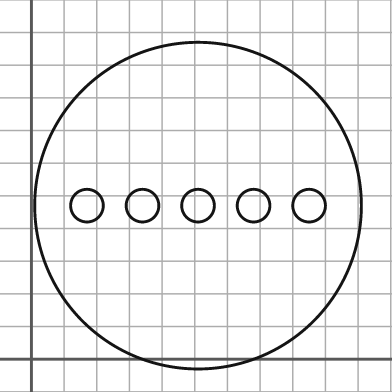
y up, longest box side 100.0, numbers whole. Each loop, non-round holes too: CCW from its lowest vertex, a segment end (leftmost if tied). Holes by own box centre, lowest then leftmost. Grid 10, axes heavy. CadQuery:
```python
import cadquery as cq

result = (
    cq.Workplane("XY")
    .moveTo(51.0, 47.0)
    .circle(50.0)
    .moveTo(17.0, 47.0)
    .circle(5.0)
    .moveTo(34.0, 47.0)
    .circle(5.0)
    .moveTo(51.0, 47.0)
    .circle(5.0)
    .moveTo(68.0, 47.0)
    .circle(5.0)
    .moveTo(85.0, 47.0)
    .circle(5.0)
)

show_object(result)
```